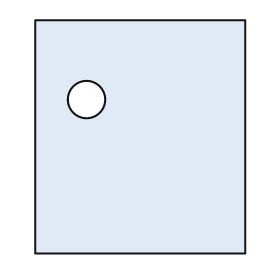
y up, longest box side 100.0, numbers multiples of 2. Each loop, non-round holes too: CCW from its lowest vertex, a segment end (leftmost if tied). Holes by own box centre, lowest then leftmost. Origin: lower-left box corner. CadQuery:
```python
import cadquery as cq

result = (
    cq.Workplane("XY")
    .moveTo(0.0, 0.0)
    .lineTo(90.0, 0.0)
    .lineTo(90.0, 100.0)
    .lineTo(0.0, 100.0)
    .close()
    .moveTo(22.0, 66.0)
    .circle(8.0)
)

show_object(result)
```